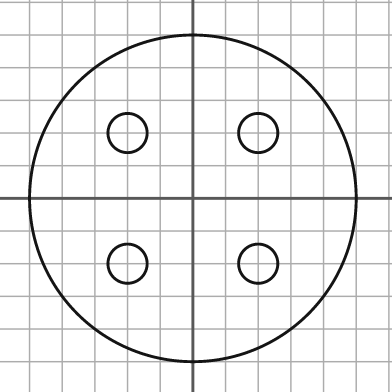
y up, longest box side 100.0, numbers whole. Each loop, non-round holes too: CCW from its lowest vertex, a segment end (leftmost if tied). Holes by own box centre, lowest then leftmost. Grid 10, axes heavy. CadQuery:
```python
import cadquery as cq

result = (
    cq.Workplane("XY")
    .moveTo(0.0, 0.0)
    .circle(50.0)
    .moveTo(-20.0, -20.0)
    .circle(6.0)
    .moveTo(20.0, -20.0)
    .circle(6.0)
    .moveTo(-20.0, 20.0)
    .circle(6.0)
    .moveTo(20.0, 20.0)
    .circle(6.0)
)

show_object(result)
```